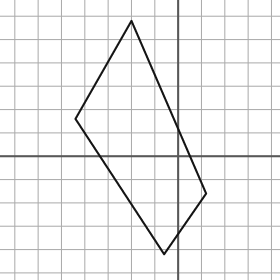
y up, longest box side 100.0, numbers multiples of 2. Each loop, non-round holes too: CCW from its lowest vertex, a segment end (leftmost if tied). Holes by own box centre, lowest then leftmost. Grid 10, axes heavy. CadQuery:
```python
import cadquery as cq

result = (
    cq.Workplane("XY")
    .moveTo(-6.0, -42.0)
    .lineTo(12.0, -16.0)
    .lineTo(-20.0, 58.0)
    .lineTo(-44.0, 16.0)
    .close()
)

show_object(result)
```